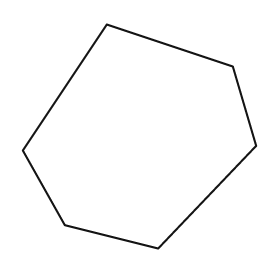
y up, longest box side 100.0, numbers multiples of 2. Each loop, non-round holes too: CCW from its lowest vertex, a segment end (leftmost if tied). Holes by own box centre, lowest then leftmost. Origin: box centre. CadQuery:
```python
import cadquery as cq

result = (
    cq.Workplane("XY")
    .moveTo(8.0, -48.0)
    .lineTo(50.0, -4.0)
    .lineTo(40.0, 30.0)
    .lineTo(-14.0, 48.0)
    .lineTo(-50.0, -6.0)
    .lineTo(-32.0, -38.0)
    .close()
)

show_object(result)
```